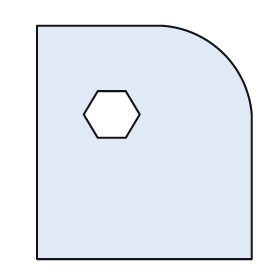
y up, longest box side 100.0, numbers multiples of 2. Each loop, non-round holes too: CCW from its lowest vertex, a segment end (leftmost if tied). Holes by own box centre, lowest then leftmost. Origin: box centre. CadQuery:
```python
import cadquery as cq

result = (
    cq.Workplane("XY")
    .moveTo(-46.0, -50.0)
    .lineTo(46.0, -50.0)
    .lineTo(46.0, 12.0)
    .threePointArc((34.0, 38.0), (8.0, 50.0))
    .lineTo(-46.0, 50.0)
    .close()
    .moveTo(-20.0, 2.0)
    .lineTo(-8.0, 2.0)
    .lineTo(-2.0, 12.0)
    .lineTo(-8.0, 22.0)
    .lineTo(-20.0, 22.0)
    .lineTo(-26.0, 12.0)
    .close()
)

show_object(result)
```